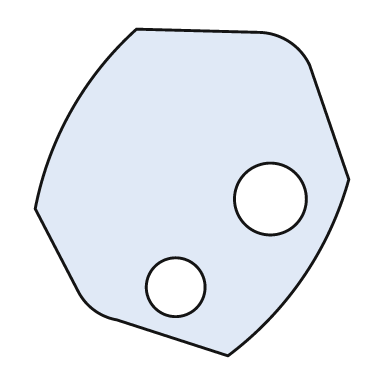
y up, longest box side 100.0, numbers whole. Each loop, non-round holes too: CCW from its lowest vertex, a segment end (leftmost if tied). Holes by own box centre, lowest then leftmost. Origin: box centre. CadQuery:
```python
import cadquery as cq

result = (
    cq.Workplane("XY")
    .moveTo(11.0, -50.0)
    .threePointArc((34.0, -26.0), (48.0, 4.0))
    .lineTo(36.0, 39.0)
    .threePointArc((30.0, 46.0), (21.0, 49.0))
    .lineTo(-17.0, 50.0)
    .threePointArc((-37.0, 25.0), (-48.0, -5.0))
    .lineTo(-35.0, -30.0)
    .threePointArc((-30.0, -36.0), (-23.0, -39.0))
    .close()
    .moveTo(-5.0, -29.0)
    .circle(9.0)
    .moveTo(24.0, -2.0)
    .circle(11.0)
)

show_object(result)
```